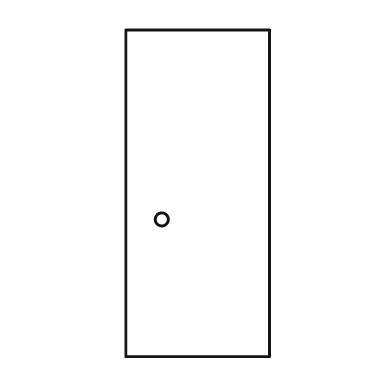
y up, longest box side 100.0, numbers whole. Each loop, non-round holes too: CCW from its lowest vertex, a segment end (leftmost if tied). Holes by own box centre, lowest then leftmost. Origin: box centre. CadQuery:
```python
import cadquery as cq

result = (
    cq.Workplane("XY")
    .moveTo(-22.0, -50.0)
    .lineTo(22.0, -50.0)
    .lineTo(22.0, 50.0)
    .lineTo(-22.0, 50.0)
    .close()
    .moveTo(-11.0, -8.0)
    .circle(2.0)
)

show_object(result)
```